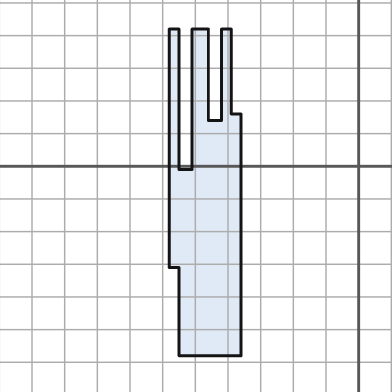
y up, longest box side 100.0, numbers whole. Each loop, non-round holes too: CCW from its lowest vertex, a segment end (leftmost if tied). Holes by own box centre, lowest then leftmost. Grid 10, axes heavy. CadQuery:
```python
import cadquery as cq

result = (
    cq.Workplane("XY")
    .moveTo(-55.0, -58.0)
    .lineTo(-36.0, -58.0)
    .lineTo(-36.0, 16.0)
    .lineTo(-39.0, 16.0)
    .lineTo(-39.0, 42.0)
    .lineTo(-42.0, 42.0)
    .lineTo(-42.0, 14.0)
    .lineTo(-46.0, 14.0)
    .lineTo(-46.0, 42.0)
    .lineTo(-51.0, 42.0)
    .lineTo(-51.0, -1.0)
    .lineTo(-55.0, -1.0)
    .lineTo(-55.0, 42.0)
    .lineTo(-58.0, 42.0)
    .lineTo(-58.0, -31.0)
    .lineTo(-55.0, -31.0)
    .close()
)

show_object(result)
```